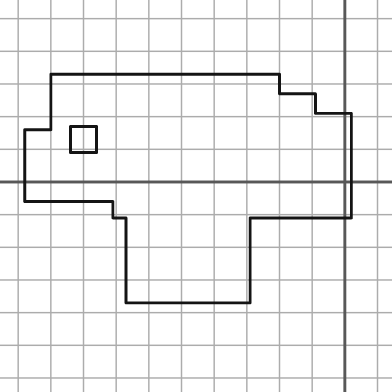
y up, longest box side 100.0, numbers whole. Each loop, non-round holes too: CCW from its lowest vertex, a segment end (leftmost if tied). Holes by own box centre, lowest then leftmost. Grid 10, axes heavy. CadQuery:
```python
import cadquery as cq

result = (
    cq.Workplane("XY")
    .moveTo(-67.0, -37.0)
    .lineTo(-29.0, -37.0)
    .lineTo(-29.0, -11.0)
    .lineTo(2.0, -11.0)
    .lineTo(2.0, 21.0)
    .lineTo(-9.0, 21.0)
    .lineTo(-9.0, 27.0)
    .lineTo(-20.0, 27.0)
    .lineTo(-20.0, 33.0)
    .lineTo(-90.0, 33.0)
    .lineTo(-90.0, 16.0)
    .lineTo(-98.0, 16.0)
    .lineTo(-98.0, -6.0)
    .lineTo(-71.0, -6.0)
    .lineTo(-71.0, -11.0)
    .lineTo(-67.0, -11.0)
    .close()
    .moveTo(-84.0, 9.0)
    .lineTo(-76.0, 9.0)
    .lineTo(-76.0, 17.0)
    .lineTo(-84.0, 17.0)
    .close()
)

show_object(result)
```